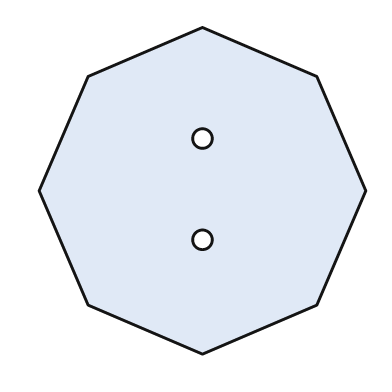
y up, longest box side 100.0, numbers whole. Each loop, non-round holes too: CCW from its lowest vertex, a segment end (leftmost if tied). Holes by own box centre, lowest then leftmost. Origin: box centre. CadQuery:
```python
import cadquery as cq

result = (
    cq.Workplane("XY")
    .moveTo(0.0, -50.0)
    .lineTo(35.0, -35.0)
    .lineTo(50.0, 0.0)
    .lineTo(35.0, 35.0)
    .lineTo(0.0, 50.0)
    .lineTo(-35.0, 35.0)
    .lineTo(-50.0, 0.0)
    .lineTo(-35.0, -35.0)
    .close()
    .moveTo(0.0, -15.0)
    .circle(3.0)
    .moveTo(0.0, 16.0)
    .circle(3.0)
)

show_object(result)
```